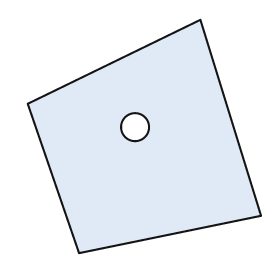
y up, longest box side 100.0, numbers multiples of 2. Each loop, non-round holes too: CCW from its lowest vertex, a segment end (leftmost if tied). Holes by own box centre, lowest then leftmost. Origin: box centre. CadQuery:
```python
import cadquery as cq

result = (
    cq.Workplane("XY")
    .moveTo(-28.0, -50.0)
    .lineTo(50.0, -34.0)
    .lineTo(24.0, 50.0)
    .lineTo(-50.0, 14.0)
    .close()
    .moveTo(-4.0, 4.0)
    .circle(6.0)
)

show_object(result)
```